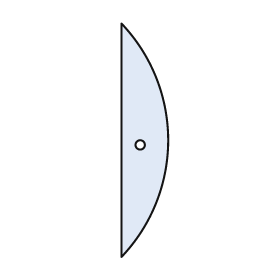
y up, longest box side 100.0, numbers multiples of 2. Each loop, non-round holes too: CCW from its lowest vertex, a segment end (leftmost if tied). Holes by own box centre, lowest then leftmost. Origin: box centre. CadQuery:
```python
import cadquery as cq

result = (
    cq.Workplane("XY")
    .moveTo(-10.0, -50.0)
    .threePointArc((10.0, 0.0), (-10.0, 50.0))
    .close()
    .moveTo(-2.0, -2.0)
    .circle(2.0)
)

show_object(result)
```